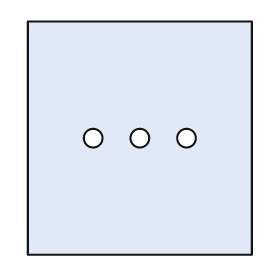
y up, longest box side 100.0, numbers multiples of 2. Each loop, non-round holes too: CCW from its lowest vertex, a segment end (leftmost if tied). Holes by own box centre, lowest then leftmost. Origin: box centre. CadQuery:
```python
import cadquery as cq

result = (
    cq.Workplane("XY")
    .moveTo(-48.0, -50.0)
    .lineTo(48.0, -50.0)
    .lineTo(48.0, 50.0)
    .lineTo(-48.0, 50.0)
    .close()
    .moveTo(-20.0, 0.0)
    .circle(4.0)
    .moveTo(0.0, 0.0)
    .circle(4.0)
    .moveTo(20.0, 0.0)
    .circle(4.0)
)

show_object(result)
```